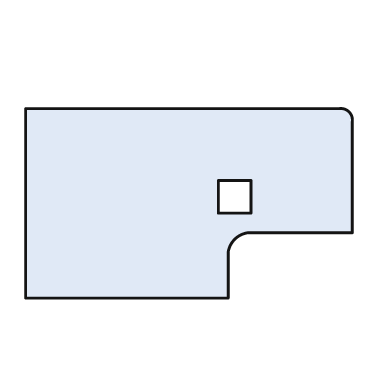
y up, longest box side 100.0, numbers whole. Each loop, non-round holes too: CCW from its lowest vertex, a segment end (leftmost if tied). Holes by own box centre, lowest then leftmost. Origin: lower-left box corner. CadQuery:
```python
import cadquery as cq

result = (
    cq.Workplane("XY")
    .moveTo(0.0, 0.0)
    .lineTo(62.0, 0.0)
    .lineTo(62.0, 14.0)
    .threePointArc((64.0, 18.0), (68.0, 20.0))
    .lineTo(100.0, 20.0)
    .lineTo(100.0, 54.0)
    .threePointArc((99.0, 57.0), (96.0, 58.0))
    .lineTo(0.0, 58.0)
    .close()
    .moveTo(59.0, 26.0)
    .lineTo(69.0, 26.0)
    .lineTo(69.0, 36.0)
    .lineTo(59.0, 36.0)
    .close()
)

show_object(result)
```